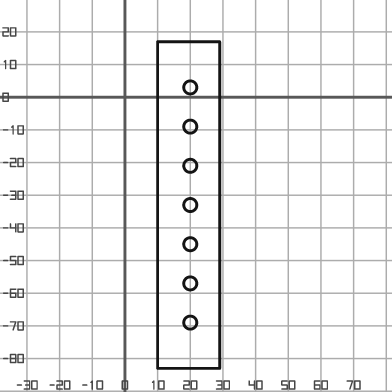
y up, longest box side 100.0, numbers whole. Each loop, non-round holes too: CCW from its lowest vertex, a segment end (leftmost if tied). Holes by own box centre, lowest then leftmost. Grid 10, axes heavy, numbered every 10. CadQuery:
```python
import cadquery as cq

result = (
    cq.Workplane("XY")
    .moveTo(10.0, -83.0)
    .lineTo(29.0, -83.0)
    .lineTo(29.0, 17.0)
    .lineTo(10.0, 17.0)
    .close()
    .moveTo(20.0, -69.0)
    .circle(2.0)
    .moveTo(20.0, -57.0)
    .circle(2.0)
    .moveTo(20.0, -45.0)
    .circle(2.0)
    .moveTo(20.0, -33.0)
    .circle(2.0)
    .moveTo(20.0, -21.0)
    .circle(2.0)
    .moveTo(20.0, -9.0)
    .circle(2.0)
    .moveTo(20.0, 3.0)
    .circle(2.0)
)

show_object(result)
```